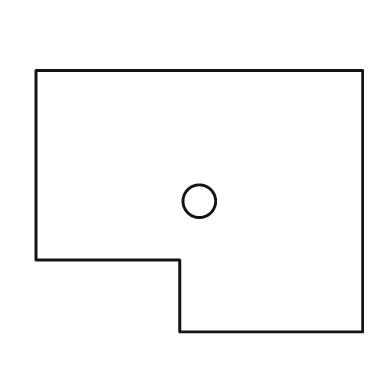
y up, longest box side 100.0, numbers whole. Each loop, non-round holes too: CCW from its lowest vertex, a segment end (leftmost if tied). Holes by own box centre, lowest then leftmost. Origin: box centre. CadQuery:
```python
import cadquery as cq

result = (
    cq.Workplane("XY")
    .moveTo(-6.0, -40.0)
    .lineTo(50.0, -40.0)
    .lineTo(50.0, 40.0)
    .lineTo(-50.0, 40.0)
    .lineTo(-50.0, -18.0)
    .lineTo(-6.0, -18.0)
    .close()
    .moveTo(0.0, 0.0)
    .circle(5.0)
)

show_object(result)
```